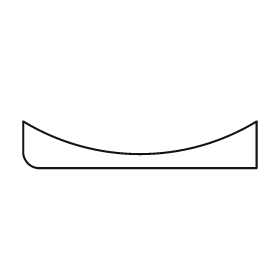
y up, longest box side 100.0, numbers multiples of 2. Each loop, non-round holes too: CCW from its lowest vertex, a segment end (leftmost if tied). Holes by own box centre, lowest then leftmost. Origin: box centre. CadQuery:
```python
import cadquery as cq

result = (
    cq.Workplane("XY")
    .moveTo(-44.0, -10.0)
    .lineTo(50.0, -10.0)
    .lineTo(50.0, 10.0)
    .threePointArc((0.0, -4.0), (-50.0, 10.0))
    .lineTo(-50.0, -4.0)
    .threePointArc((-48.0, -8.0), (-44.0, -10.0))
    .close()
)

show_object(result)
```